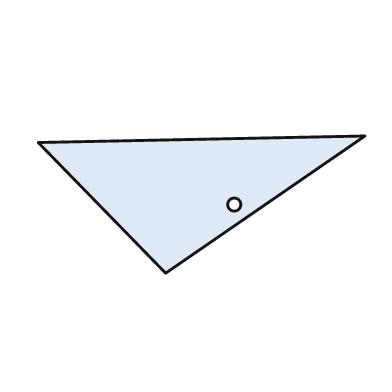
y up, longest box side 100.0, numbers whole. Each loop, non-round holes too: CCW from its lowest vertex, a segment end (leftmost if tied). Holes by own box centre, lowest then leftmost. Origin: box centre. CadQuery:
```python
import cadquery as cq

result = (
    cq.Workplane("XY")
    .moveTo(-11.0, -21.0)
    .lineTo(50.0, 21.0)
    .lineTo(-50.0, 19.0)
    .close()
    .moveTo(10.0, 0.0)
    .circle(2.0)
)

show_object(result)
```